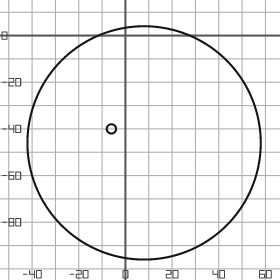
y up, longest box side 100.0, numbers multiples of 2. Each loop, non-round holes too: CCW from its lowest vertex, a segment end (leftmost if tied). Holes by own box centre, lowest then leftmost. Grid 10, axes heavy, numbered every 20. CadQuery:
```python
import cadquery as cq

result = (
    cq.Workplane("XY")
    .moveTo(8.0, -46.0)
    .circle(50.0)
    .moveTo(-6.0, -40.0)
    .circle(2.0)
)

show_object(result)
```